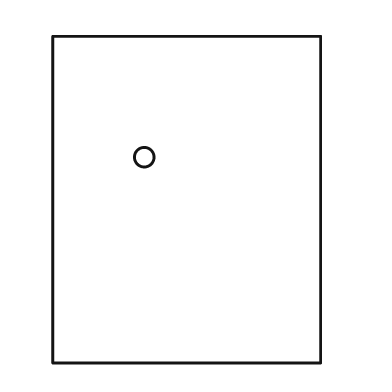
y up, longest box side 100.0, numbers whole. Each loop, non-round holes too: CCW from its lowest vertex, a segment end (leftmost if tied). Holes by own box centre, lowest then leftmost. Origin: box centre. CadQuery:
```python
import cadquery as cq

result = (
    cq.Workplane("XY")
    .moveTo(-41.0, -50.0)
    .lineTo(41.0, -50.0)
    .lineTo(41.0, 50.0)
    .lineTo(-41.0, 50.0)
    .close()
    .moveTo(-13.0, 13.0)
    .circle(3.0)
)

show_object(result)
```